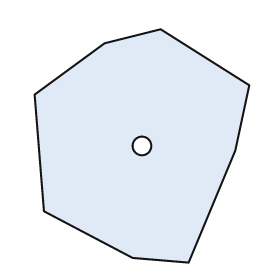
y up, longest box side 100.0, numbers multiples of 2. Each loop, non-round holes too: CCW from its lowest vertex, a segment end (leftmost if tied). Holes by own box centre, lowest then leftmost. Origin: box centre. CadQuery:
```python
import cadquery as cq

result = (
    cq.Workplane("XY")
    .moveTo(20.0, -50.0)
    .lineTo(40.0, -2.0)
    .lineTo(46.0, 26.0)
    .lineTo(8.0, 50.0)
    .lineTo(-16.0, 44.0)
    .lineTo(-46.0, 22.0)
    .lineTo(-42.0, -28.0)
    .lineTo(-4.0, -48.0)
    .close()
    .moveTo(0.0, 0.0)
    .circle(4.0)
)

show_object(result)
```